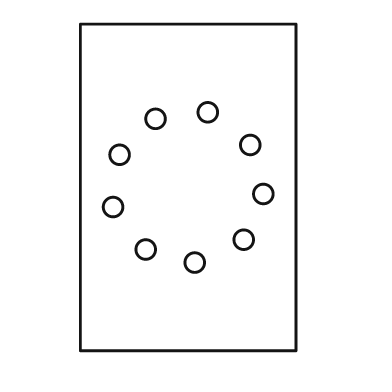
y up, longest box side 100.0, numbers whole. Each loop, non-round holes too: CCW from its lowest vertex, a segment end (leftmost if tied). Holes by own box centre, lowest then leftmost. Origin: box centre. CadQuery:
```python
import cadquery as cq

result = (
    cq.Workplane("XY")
    .moveTo(-33.0, -50.0)
    .lineTo(33.0, -50.0)
    .lineTo(33.0, 50.0)
    .lineTo(-33.0, 50.0)
    .close()
    .moveTo(2.0, -23.0)
    .circle(3.0)
    .moveTo(-13.0, -19.0)
    .circle(3.0)
    .moveTo(17.0, -16.0)
    .circle(3.0)
    .moveTo(-23.0, -6.0)
    .circle(3.0)
    .moveTo(23.0, -2.0)
    .circle(3.0)
    .moveTo(-21.0, 10.0)
    .circle(3.0)
    .moveTo(19.0, 13.0)
    .circle(3.0)
    .moveTo(-10.0, 21.0)
    .circle(3.0)
    .moveTo(6.0, 23.0)
    .circle(3.0)
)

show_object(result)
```